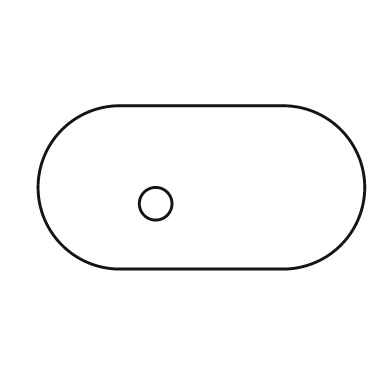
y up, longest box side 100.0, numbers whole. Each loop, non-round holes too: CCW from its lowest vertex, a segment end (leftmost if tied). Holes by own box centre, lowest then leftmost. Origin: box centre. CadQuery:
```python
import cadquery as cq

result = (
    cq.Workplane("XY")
    .moveTo(-25.0, -25.0)
    .lineTo(25.0, -25.0)
    .threePointArc((50.0, 0.0), (25.0, 25.0))
    .lineTo(-25.0, 25.0)
    .threePointArc((-50.0, 0.0), (-25.0, -25.0))
    .close()
    .moveTo(-14.0, -5.0)
    .circle(5.0)
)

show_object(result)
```